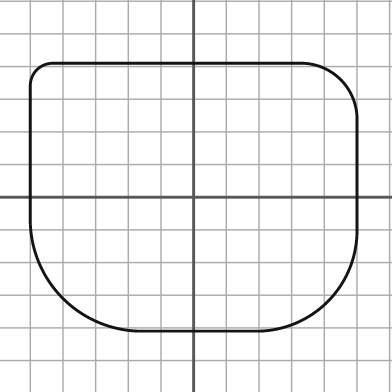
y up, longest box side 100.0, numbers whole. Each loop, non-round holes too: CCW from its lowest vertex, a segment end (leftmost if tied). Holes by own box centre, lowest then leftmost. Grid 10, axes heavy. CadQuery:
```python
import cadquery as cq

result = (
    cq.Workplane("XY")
    .moveTo(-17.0, -41.0)
    .lineTo(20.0, -41.0)
    .threePointArc((41.0, -32.0), (50.0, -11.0))
    .lineTo(50.0, 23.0)
    .threePointArc((45.0, 36.0), (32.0, 41.0))
    .lineTo(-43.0, 41.0)
    .threePointArc((-48.0, 39.0), (-50.0, 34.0))
    .lineTo(-50.0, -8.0)
    .threePointArc((-40.0, -31.0), (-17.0, -41.0))
    .close()
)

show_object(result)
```